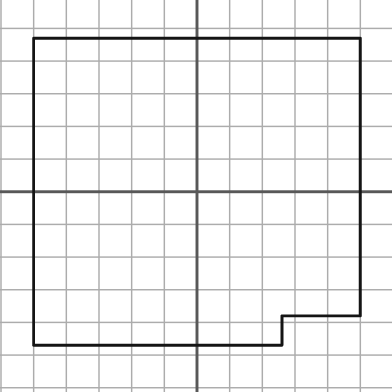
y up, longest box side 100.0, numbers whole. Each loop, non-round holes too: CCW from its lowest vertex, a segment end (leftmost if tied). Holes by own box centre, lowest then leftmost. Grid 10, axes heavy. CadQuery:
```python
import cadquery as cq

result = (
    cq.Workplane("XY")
    .moveTo(-50.0, -47.0)
    .lineTo(26.0, -47.0)
    .lineTo(26.0, -38.0)
    .lineTo(50.0, -38.0)
    .lineTo(50.0, 47.0)
    .lineTo(-50.0, 47.0)
    .close()
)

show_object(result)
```